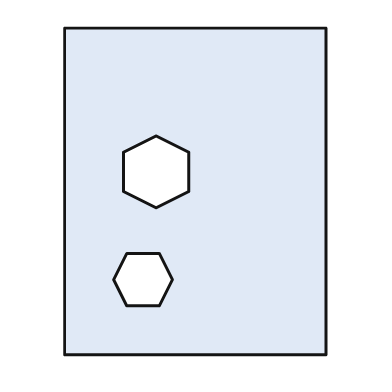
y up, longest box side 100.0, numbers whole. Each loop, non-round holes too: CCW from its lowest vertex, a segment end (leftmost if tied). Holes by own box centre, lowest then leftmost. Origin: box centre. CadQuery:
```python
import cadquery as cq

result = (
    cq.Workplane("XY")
    .moveTo(-40.0, -50.0)
    .lineTo(40.0, -50.0)
    .lineTo(40.0, 50.0)
    .lineTo(-40.0, 50.0)
    .close()
    .moveTo(-21.0, -35.0)
    .lineTo(-11.0, -35.0)
    .lineTo(-7.0, -27.0)
    .lineTo(-11.0, -19.0)
    .lineTo(-21.0, -19.0)
    .lineTo(-25.0, -27.0)
    .close()
    .moveTo(-12.0, -5.0)
    .lineTo(-2.0, 0.0)
    .lineTo(-2.0, 12.0)
    .lineTo(-12.0, 17.0)
    .lineTo(-22.0, 12.0)
    .lineTo(-22.0, 0.0)
    .close()
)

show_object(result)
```